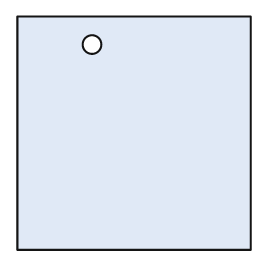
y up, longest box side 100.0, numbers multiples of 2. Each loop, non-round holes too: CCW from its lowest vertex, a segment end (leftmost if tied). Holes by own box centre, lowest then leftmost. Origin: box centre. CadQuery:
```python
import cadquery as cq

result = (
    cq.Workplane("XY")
    .moveTo(-50.0, -50.0)
    .lineTo(50.0, -50.0)
    .lineTo(50.0, 50.0)
    .lineTo(-50.0, 50.0)
    .close()
    .moveTo(-18.0, 38.0)
    .circle(4.0)
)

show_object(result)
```